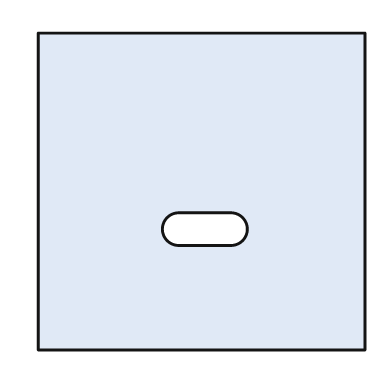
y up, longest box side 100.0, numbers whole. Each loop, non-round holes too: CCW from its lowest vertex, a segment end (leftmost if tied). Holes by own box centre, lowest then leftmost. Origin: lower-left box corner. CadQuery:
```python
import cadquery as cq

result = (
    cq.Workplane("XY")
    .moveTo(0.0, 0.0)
    .lineTo(100.0, 0.0)
    .lineTo(100.0, 97.0)
    .lineTo(0.0, 97.0)
    .close()
    .moveTo(43.0, 32.0)
    .lineTo(59.0, 32.0)
    .threePointArc((64.0, 37.0), (59.0, 42.0))
    .lineTo(43.0, 42.0)
    .threePointArc((38.0, 37.0), (43.0, 32.0))
    .close()
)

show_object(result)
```